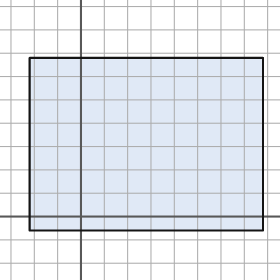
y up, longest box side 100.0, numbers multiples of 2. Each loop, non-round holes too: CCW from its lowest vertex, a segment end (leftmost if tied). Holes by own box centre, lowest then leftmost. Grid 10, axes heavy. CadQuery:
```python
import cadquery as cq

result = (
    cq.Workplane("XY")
    .moveTo(-22.0, -6.0)
    .lineTo(78.0, -6.0)
    .lineTo(78.0, 68.0)
    .lineTo(-22.0, 68.0)
    .close()
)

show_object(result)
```